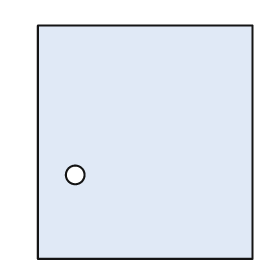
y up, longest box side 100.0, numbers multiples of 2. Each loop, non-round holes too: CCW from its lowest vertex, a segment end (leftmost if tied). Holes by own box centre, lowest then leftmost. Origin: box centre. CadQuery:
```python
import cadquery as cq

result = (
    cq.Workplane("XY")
    .moveTo(-46.0, -50.0)
    .lineTo(46.0, -50.0)
    .lineTo(46.0, 50.0)
    .lineTo(-46.0, 50.0)
    .close()
    .moveTo(-30.0, -14.0)
    .circle(4.0)
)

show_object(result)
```